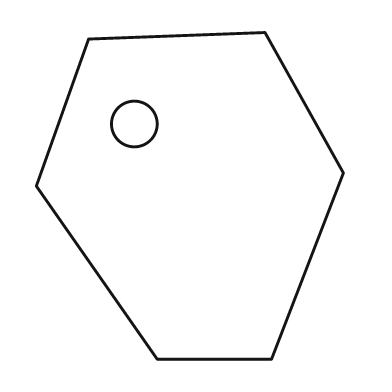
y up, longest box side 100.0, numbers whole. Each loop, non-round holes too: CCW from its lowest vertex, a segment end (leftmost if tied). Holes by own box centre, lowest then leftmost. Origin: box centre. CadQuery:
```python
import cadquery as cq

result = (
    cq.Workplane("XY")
    .moveTo(-10.0, -50.0)
    .lineTo(25.0, -50.0)
    .lineTo(47.0, 7.0)
    .lineTo(23.0, 50.0)
    .lineTo(-31.0, 48.0)
    .lineTo(-47.0, 3.0)
    .close()
    .moveTo(-17.0, 22.0)
    .circle(7.0)
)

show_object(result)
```